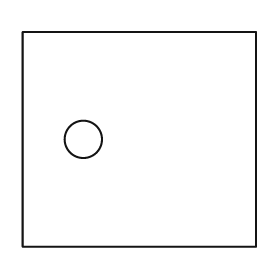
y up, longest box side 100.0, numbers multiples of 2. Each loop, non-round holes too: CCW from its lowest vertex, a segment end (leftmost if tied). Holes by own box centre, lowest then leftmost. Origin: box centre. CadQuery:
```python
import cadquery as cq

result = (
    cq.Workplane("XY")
    .moveTo(-50.0, -46.0)
    .lineTo(50.0, -46.0)
    .lineTo(50.0, 46.0)
    .lineTo(-50.0, 46.0)
    .close()
    .moveTo(-24.0, 0.0)
    .circle(8.0)
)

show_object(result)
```